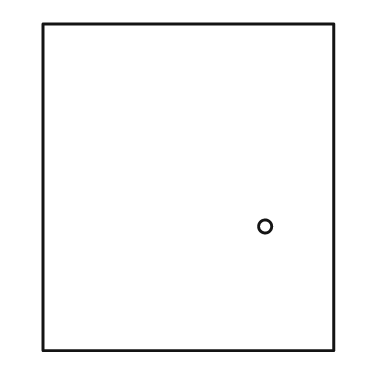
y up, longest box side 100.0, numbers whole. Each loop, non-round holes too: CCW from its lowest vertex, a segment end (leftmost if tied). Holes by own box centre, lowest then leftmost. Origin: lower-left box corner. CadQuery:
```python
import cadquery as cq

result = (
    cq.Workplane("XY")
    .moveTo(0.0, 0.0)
    .lineTo(89.0, 0.0)
    .lineTo(89.0, 100.0)
    .lineTo(0.0, 100.0)
    .close()
    .moveTo(68.0, 38.0)
    .circle(2.0)
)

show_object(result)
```